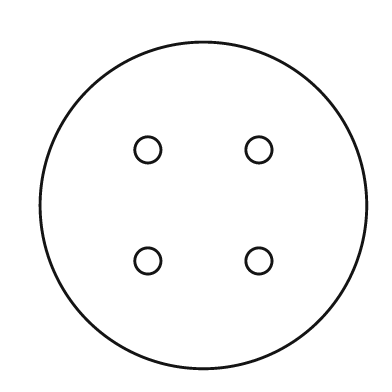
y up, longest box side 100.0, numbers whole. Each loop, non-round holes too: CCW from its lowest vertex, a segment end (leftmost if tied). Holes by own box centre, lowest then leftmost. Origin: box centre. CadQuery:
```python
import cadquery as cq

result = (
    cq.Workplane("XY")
    .moveTo(0.0, 0.0)
    .circle(50.0)
    .moveTo(-17.0, -17.0)
    .circle(4.0)
    .moveTo(17.0, -17.0)
    .circle(4.0)
    .moveTo(-17.0, 17.0)
    .circle(4.0)
    .moveTo(17.0, 17.0)
    .circle(4.0)
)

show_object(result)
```